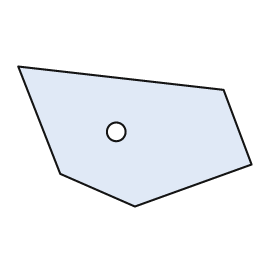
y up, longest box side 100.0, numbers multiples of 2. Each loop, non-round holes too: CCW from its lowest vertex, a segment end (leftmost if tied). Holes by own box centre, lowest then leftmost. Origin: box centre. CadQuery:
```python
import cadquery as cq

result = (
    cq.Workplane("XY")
    .moveTo(0.0, -30.0)
    .lineTo(50.0, -12.0)
    .lineTo(38.0, 20.0)
    .lineTo(-50.0, 30.0)
    .lineTo(-32.0, -16.0)
    .close()
    .moveTo(-8.0, 2.0)
    .circle(4.0)
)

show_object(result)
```